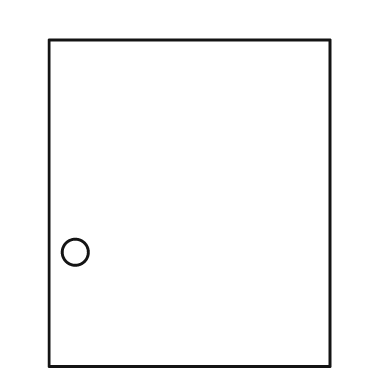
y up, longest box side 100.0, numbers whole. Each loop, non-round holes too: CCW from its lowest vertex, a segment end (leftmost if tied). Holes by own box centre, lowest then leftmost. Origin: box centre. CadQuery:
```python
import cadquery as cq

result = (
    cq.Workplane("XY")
    .moveTo(-43.0, -50.0)
    .lineTo(43.0, -50.0)
    .lineTo(43.0, 50.0)
    .lineTo(-43.0, 50.0)
    .close()
    .moveTo(-35.0, -15.0)
    .circle(4.0)
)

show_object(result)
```